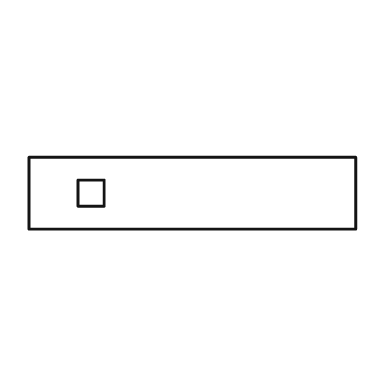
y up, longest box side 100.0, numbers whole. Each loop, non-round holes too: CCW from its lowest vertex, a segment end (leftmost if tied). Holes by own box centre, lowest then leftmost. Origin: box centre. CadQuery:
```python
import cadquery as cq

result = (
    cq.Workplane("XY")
    .moveTo(-50.0, -11.0)
    .lineTo(50.0, -11.0)
    .lineTo(50.0, 11.0)
    .lineTo(-50.0, 11.0)
    .close()
    .moveTo(-35.0, -4.0)
    .lineTo(-27.0, -4.0)
    .lineTo(-27.0, 4.0)
    .lineTo(-35.0, 4.0)
    .close()
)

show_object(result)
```